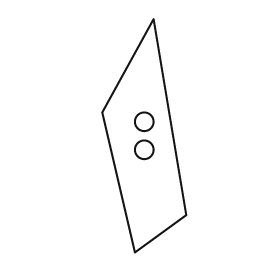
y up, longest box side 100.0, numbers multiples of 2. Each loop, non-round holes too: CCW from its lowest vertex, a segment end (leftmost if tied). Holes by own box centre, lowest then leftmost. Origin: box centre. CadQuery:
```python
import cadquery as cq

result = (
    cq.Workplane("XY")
    .moveTo(-4.0, -50.0)
    .lineTo(18.0, -34.0)
    .lineTo(4.0, 50.0)
    .lineTo(-18.0, 10.0)
    .close()
    .moveTo(0.0, -6.0)
    .circle(4.0)
    .moveTo(0.0, 6.0)
    .circle(4.0)
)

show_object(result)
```